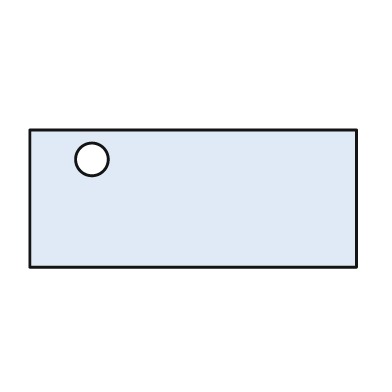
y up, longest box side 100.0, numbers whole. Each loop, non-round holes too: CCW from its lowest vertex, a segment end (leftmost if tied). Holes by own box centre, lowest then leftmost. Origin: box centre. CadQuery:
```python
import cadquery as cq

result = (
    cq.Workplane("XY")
    .moveTo(-50.0, -21.0)
    .lineTo(50.0, -21.0)
    .lineTo(50.0, 21.0)
    .lineTo(-50.0, 21.0)
    .close()
    .moveTo(-31.0, 12.0)
    .circle(5.0)
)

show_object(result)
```